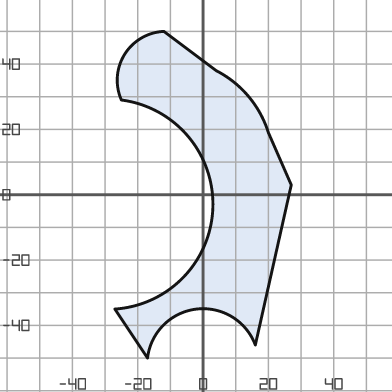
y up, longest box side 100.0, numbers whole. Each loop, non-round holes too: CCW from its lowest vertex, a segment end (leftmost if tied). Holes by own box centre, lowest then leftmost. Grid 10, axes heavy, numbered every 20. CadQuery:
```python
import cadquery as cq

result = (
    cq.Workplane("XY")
    .moveTo(-17.0, -50.0)
    .threePointArc((-2.0, -35.0), (16.0, -46.0))
    .lineTo(27.0, 3.0)
    .lineTo(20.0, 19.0)
    .threePointArc((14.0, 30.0), (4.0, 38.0))
    .lineTo(-12.0, 50.0)
    .threePointArc((-24.0, 43.0), (-25.0, 29.0))
    .threePointArc((3.0, -4.0), (-27.0, -35.0))
    .close()
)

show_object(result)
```